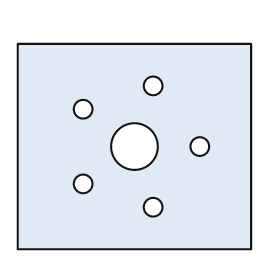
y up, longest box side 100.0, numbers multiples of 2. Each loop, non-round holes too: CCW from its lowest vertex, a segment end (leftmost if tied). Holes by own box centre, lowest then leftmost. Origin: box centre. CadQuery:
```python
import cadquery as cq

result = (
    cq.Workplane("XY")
    .moveTo(-50.0, -44.0)
    .lineTo(50.0, -44.0)
    .lineTo(50.0, 44.0)
    .lineTo(-50.0, 44.0)
    .close()
    .moveTo(8.0, -26.0)
    .circle(4.0)
    .moveTo(-22.0, -16.0)
    .circle(4.0)
    .moveTo(0.0, 0.0)
    .circle(10.0)
    .moveTo(28.0, 0.0)
    .circle(4.0)
    .moveTo(-22.0, 16.0)
    .circle(4.0)
    .moveTo(8.0, 26.0)
    .circle(4.0)
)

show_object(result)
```